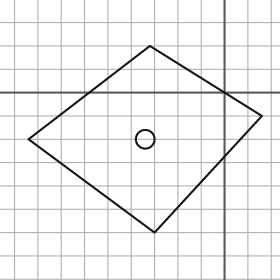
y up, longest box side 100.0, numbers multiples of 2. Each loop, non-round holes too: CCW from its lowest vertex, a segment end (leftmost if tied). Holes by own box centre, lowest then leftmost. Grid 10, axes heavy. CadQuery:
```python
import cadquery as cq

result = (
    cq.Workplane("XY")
    .moveTo(-30.0, -60.0)
    .lineTo(16.0, -10.0)
    .lineTo(-32.0, 20.0)
    .lineTo(-84.0, -20.0)
    .close()
    .moveTo(-34.0, -20.0)
    .circle(4.0)
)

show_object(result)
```